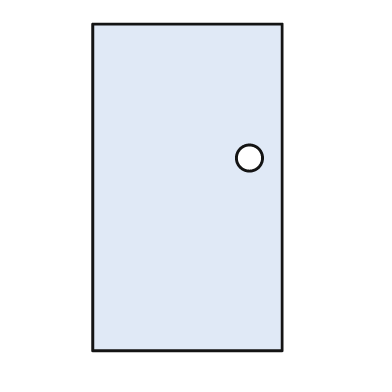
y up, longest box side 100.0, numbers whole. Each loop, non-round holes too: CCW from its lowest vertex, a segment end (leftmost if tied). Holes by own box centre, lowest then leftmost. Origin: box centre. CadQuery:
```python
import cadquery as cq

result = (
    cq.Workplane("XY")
    .moveTo(-29.0, -50.0)
    .lineTo(29.0, -50.0)
    .lineTo(29.0, 50.0)
    .lineTo(-29.0, 50.0)
    .close()
    .moveTo(19.0, 9.0)
    .circle(4.0)
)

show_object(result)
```